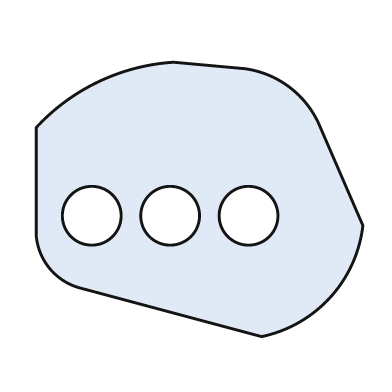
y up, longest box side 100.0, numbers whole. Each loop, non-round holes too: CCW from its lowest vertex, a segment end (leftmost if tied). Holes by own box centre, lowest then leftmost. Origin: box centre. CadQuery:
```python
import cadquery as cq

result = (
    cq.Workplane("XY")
    .moveTo(19.0, -42.0)
    .threePointArc((40.0, -30.0), (50.0, -8.0))
    .lineTo(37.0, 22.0)
    .threePointArc((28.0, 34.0), (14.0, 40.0))
    .lineTo(-8.0, 42.0)
    .threePointArc((-31.0, 36.0), (-50.0, 22.0))
    .lineTo(-50.0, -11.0)
    .threePointArc((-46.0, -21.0), (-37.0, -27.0))
    .close()
    .moveTo(-33.0, -5.0)
    .circle(9.0)
    .moveTo(-9.0, -5.0)
    .circle(9.0)
    .moveTo(15.0, -5.0)
    .circle(9.0)
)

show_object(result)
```